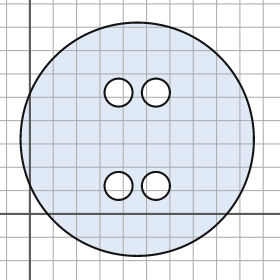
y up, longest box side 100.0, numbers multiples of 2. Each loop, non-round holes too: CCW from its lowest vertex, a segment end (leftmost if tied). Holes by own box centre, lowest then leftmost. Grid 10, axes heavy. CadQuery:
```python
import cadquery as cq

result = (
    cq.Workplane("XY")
    .moveTo(46.0, 32.0)
    .circle(50.0)
    .moveTo(38.0, 12.0)
    .circle(6.0)
    .moveTo(54.0, 12.0)
    .circle(6.0)
    .moveTo(38.0, 52.0)
    .circle(6.0)
    .moveTo(54.0, 52.0)
    .circle(6.0)
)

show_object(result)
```